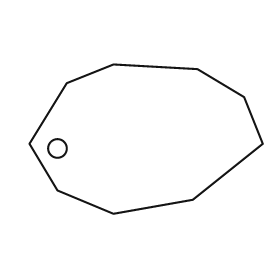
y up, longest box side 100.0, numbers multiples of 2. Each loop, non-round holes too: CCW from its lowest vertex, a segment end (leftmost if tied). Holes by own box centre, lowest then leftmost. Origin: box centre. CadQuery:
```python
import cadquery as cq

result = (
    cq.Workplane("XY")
    .moveTo(-14.0, -32.0)
    .lineTo(20.0, -26.0)
    .lineTo(50.0, -2.0)
    .lineTo(42.0, 18.0)
    .lineTo(22.0, 30.0)
    .lineTo(-14.0, 32.0)
    .lineTo(-34.0, 24.0)
    .lineTo(-50.0, -2.0)
    .lineTo(-38.0, -22.0)
    .close()
    .moveTo(-38.0, -4.0)
    .circle(4.0)
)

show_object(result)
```